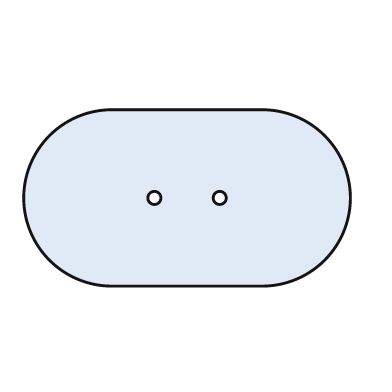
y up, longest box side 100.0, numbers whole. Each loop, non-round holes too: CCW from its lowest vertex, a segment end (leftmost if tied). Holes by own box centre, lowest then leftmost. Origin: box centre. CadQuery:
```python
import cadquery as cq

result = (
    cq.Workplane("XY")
    .moveTo(-23.0, -27.0)
    .lineTo(23.0, -27.0)
    .threePointArc((50.0, 0.0), (23.0, 27.0))
    .lineTo(-23.0, 27.0)
    .threePointArc((-50.0, 0.0), (-23.0, -27.0))
    .close()
    .moveTo(-10.0, 0.0)
    .circle(2.0)
    .moveTo(10.0, 0.0)
    .circle(2.0)
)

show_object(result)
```